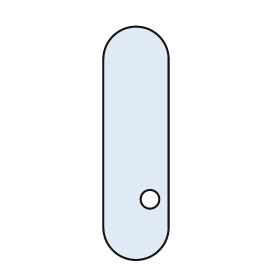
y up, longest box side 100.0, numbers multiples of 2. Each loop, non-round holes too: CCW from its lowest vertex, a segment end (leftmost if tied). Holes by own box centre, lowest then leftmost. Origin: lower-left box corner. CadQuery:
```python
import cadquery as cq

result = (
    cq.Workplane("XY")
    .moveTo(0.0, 14.0)
    .threePointArc((14.0, 0.0), (28.0, 14.0))
    .lineTo(28.0, 86.0)
    .threePointArc((14.0, 100.0), (0.0, 86.0))
    .close()
    .moveTo(20.0, 26.0)
    .circle(4.0)
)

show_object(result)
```